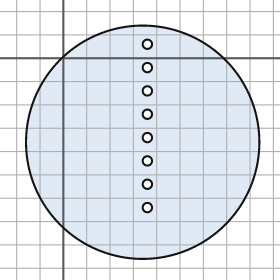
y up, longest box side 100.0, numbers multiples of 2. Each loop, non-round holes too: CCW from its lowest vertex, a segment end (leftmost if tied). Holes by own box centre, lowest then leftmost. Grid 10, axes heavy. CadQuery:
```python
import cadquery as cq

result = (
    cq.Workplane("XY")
    .moveTo(34.0, -36.0)
    .circle(50.0)
    .moveTo(36.0, -64.0)
    .circle(2.0)
    .moveTo(36.0, -54.0)
    .circle(2.0)
    .moveTo(36.0, -44.0)
    .circle(2.0)
    .moveTo(36.0, -34.0)
    .circle(2.0)
    .moveTo(36.0, -24.0)
    .circle(2.0)
    .moveTo(36.0, -14.0)
    .circle(2.0)
    .moveTo(36.0, -4.0)
    .circle(2.0)
    .moveTo(36.0, 6.0)
    .circle(2.0)
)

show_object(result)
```